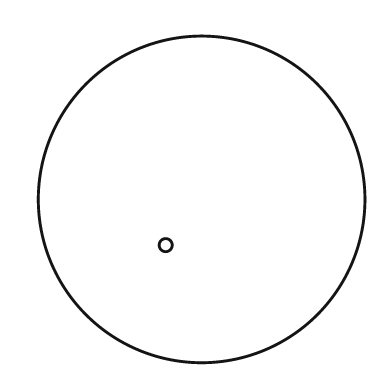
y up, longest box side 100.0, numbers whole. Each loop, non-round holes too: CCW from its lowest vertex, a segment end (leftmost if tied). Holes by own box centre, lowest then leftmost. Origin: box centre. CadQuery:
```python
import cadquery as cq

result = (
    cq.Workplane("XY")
    .moveTo(0.0, 0.0)
    .circle(50.0)
    .moveTo(-11.0, -14.0)
    .circle(2.0)
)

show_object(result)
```